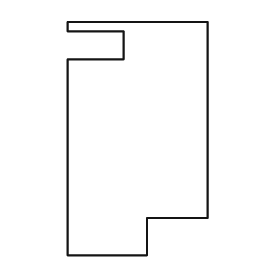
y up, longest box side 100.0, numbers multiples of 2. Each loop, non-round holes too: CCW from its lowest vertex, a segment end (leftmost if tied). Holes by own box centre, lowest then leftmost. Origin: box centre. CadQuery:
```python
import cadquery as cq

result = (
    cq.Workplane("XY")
    .moveTo(-30.0, -50.0)
    .lineTo(4.0, -50.0)
    .lineTo(4.0, -34.0)
    .lineTo(30.0, -34.0)
    .lineTo(30.0, 50.0)
    .lineTo(-30.0, 50.0)
    .lineTo(-30.0, 46.0)
    .lineTo(-6.0, 46.0)
    .lineTo(-6.0, 34.0)
    .lineTo(-30.0, 34.0)
    .close()
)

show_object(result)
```